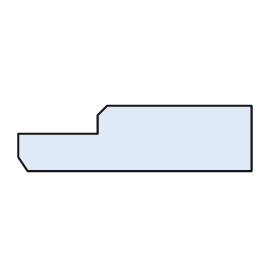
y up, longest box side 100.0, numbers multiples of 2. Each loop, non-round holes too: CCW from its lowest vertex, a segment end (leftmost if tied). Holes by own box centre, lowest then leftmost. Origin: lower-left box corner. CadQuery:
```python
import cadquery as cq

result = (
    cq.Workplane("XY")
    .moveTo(4.0, 0.0)
    .lineTo(100.0, 0.0)
    .lineTo(100.0, 28.0)
    .lineTo(38.0, 28.0)
    .lineTo(34.0, 24.0)
    .lineTo(34.0, 16.0)
    .lineTo(0.0, 16.0)
    .lineTo(0.0, 6.0)
    .close()
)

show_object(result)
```